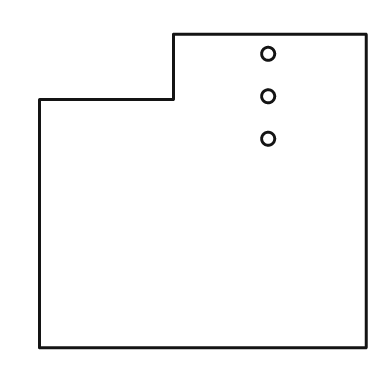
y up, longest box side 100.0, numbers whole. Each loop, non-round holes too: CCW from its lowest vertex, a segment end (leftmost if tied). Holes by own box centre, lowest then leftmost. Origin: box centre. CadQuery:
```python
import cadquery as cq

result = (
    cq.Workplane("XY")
    .moveTo(-50.0, -48.0)
    .lineTo(50.0, -48.0)
    .lineTo(50.0, 48.0)
    .lineTo(-9.0, 48.0)
    .lineTo(-9.0, 28.0)
    .lineTo(-50.0, 28.0)
    .close()
    .moveTo(20.0, 16.0)
    .circle(2.0)
    .moveTo(20.0, 29.0)
    .circle(2.0)
    .moveTo(20.0, 42.0)
    .circle(2.0)
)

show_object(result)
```